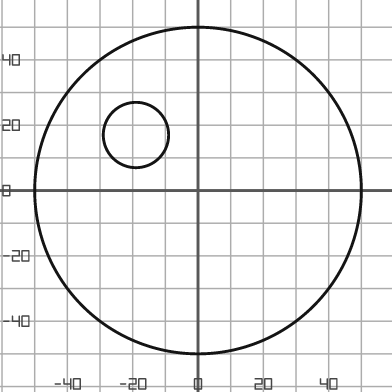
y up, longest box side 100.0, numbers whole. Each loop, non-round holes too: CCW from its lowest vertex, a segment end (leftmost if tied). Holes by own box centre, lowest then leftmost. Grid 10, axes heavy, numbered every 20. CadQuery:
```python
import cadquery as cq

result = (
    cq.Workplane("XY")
    .moveTo(0.0, 0.0)
    .circle(50.0)
    .moveTo(-19.0, 17.0)
    .circle(10.0)
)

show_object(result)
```